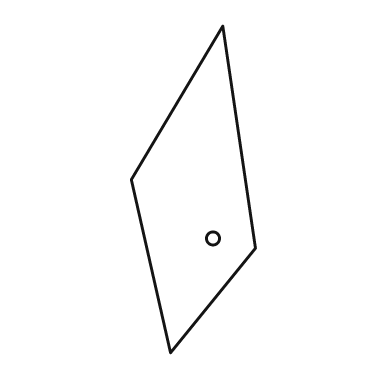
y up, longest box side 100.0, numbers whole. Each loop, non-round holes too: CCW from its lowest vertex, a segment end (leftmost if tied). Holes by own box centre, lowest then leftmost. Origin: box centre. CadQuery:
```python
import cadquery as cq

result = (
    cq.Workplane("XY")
    .moveTo(-7.0, -50.0)
    .lineTo(19.0, -18.0)
    .lineTo(9.0, 50.0)
    .lineTo(-19.0, 3.0)
    .close()
    .moveTo(6.0, -15.0)
    .circle(2.0)
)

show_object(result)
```